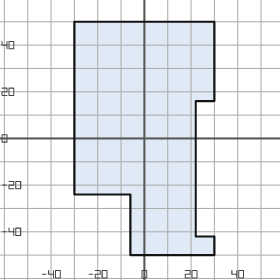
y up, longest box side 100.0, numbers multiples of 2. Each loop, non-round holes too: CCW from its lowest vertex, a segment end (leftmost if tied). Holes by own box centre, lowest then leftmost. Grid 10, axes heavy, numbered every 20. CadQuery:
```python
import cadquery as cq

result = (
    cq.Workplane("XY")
    .moveTo(-6.0, -50.0)
    .lineTo(30.0, -50.0)
    .lineTo(30.0, -42.0)
    .lineTo(22.0, -42.0)
    .lineTo(22.0, 16.0)
    .lineTo(30.0, 16.0)
    .lineTo(30.0, 50.0)
    .lineTo(-30.0, 50.0)
    .lineTo(-30.0, -24.0)
    .lineTo(-6.0, -24.0)
    .close()
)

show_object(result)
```